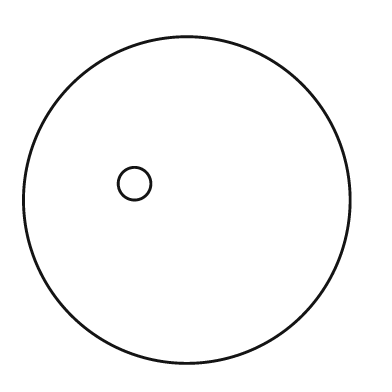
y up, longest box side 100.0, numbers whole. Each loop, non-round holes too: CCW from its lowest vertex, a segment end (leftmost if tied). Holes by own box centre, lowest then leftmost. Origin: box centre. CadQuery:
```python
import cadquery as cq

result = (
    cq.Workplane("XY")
    .moveTo(0.0, 0.0)
    .circle(50.0)
    .moveTo(-16.0, 5.0)
    .circle(5.0)
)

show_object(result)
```